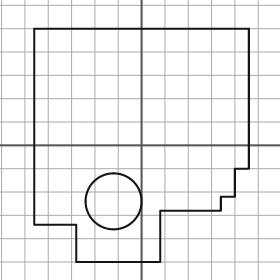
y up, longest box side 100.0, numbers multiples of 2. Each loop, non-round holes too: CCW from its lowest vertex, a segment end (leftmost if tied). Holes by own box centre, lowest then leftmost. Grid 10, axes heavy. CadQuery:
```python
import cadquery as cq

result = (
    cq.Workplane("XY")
    .moveTo(-28.0, -50.0)
    .lineTo(8.0, -50.0)
    .lineTo(8.0, -28.0)
    .lineTo(34.0, -28.0)
    .lineTo(34.0, -22.0)
    .lineTo(40.0, -22.0)
    .lineTo(40.0, -10.0)
    .lineTo(46.0, -10.0)
    .lineTo(46.0, 50.0)
    .lineTo(-46.0, 50.0)
    .lineTo(-46.0, -34.0)
    .lineTo(-28.0, -34.0)
    .close()
    .moveTo(-12.0, -24.0)
    .circle(12.0)
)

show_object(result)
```